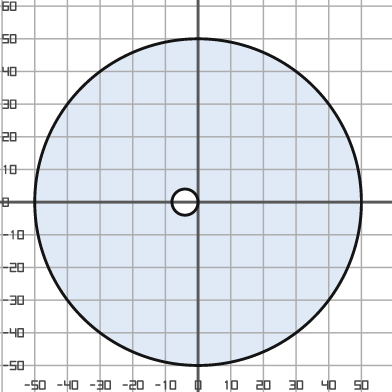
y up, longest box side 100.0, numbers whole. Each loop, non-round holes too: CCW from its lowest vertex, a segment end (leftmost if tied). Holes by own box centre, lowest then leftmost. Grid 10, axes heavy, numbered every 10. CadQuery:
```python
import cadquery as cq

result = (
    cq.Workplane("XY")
    .moveTo(0.0, 0.0)
    .circle(50.0)
    .moveTo(-4.0, 0.0)
    .circle(4.0)
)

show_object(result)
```